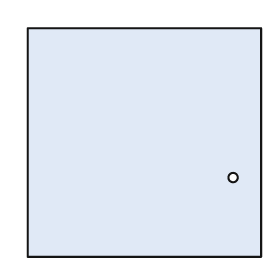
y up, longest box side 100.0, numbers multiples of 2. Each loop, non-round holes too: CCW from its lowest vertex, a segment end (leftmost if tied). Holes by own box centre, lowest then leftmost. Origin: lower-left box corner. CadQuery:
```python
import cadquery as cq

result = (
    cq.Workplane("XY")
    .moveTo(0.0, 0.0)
    .lineTo(100.0, 0.0)
    .lineTo(100.0, 98.0)
    .lineTo(0.0, 98.0)
    .close()
    .moveTo(88.0, 34.0)
    .circle(2.0)
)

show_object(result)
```